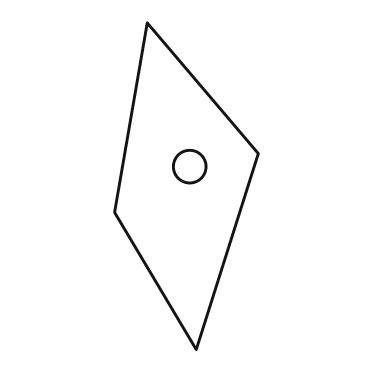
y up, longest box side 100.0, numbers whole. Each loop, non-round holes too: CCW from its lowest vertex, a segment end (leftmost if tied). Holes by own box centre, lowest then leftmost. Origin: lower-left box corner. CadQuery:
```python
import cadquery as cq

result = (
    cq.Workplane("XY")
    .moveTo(25.0, 0.0)
    .lineTo(44.0, 60.0)
    .lineTo(10.0, 100.0)
    .lineTo(0.0, 42.0)
    .close()
    .moveTo(23.0, 56.0)
    .circle(5.0)
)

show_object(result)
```